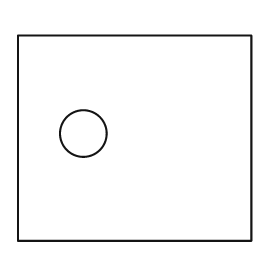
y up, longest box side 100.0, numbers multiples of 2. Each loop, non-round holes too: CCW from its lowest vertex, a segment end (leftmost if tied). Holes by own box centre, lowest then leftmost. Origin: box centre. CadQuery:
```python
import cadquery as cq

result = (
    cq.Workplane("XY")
    .moveTo(-50.0, -44.0)
    .lineTo(50.0, -44.0)
    .lineTo(50.0, 44.0)
    .lineTo(-50.0, 44.0)
    .close()
    .moveTo(-22.0, 2.0)
    .circle(10.0)
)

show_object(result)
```